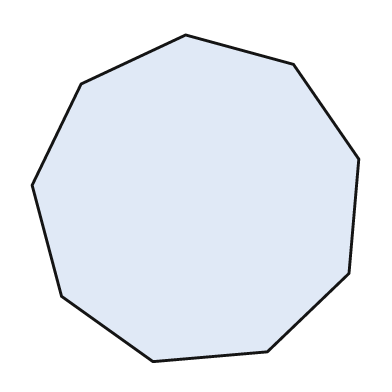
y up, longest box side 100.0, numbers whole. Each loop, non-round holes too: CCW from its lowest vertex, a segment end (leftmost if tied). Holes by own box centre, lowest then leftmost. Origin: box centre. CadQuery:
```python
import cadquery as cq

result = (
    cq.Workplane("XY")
    .moveTo(-13.0, -50.0)
    .lineTo(22.0, -47.0)
    .lineTo(47.0, -23.0)
    .lineTo(50.0, 12.0)
    .lineTo(30.0, 41.0)
    .lineTo(-3.0, 50.0)
    .lineTo(-35.0, 35.0)
    .lineTo(-50.0, 4.0)
    .lineTo(-41.0, -30.0)
    .close()
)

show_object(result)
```